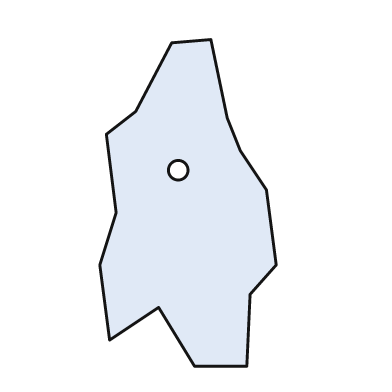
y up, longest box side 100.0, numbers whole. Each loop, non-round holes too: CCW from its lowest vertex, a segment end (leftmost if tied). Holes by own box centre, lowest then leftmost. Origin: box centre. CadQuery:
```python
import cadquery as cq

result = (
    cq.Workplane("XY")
    .moveTo(2.0, -50.0)
    .lineTo(18.0, -50.0)
    .lineTo(19.0, -28.0)
    .lineTo(27.0, -19.0)
    .lineTo(24.0, 4.0)
    .lineTo(16.0, 16.0)
    .lineTo(12.0, 26.0)
    .lineTo(7.0, 50.0)
    .lineTo(-5.0, 49.0)
    .lineTo(-16.0, 28.0)
    .lineTo(-25.0, 21.0)
    .lineTo(-22.0, -3.0)
    .lineTo(-27.0, -19.0)
    .lineTo(-24.0, -42.0)
    .lineTo(-9.0, -32.0)
    .close()
    .moveTo(-3.0, 10.0)
    .circle(3.0)
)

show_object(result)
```